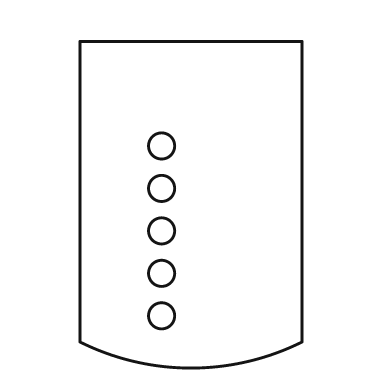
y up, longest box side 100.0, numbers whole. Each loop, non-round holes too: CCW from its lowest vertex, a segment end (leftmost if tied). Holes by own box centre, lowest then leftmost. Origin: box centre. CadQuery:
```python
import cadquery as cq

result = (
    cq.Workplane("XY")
    .moveTo(-34.0, -42.0)
    .threePointArc((0.0, -50.0), (34.0, -42.0))
    .lineTo(34.0, 50.0)
    .lineTo(-34.0, 50.0)
    .close()
    .moveTo(-9.0, -34.0)
    .circle(4.0)
    .moveTo(-9.0, -21.0)
    .circle(4.0)
    .moveTo(-9.0, -8.0)
    .circle(4.0)
    .moveTo(-9.0, 5.0)
    .circle(4.0)
    .moveTo(-9.0, 18.0)
    .circle(4.0)
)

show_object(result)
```